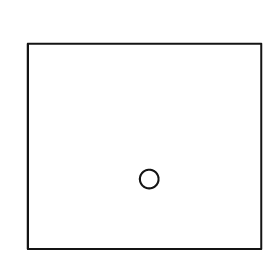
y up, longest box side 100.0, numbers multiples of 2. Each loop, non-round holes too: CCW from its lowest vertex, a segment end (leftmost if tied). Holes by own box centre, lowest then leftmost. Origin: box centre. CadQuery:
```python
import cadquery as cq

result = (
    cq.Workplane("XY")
    .moveTo(-50.0, -44.0)
    .lineTo(50.0, -44.0)
    .lineTo(50.0, 44.0)
    .lineTo(-50.0, 44.0)
    .close()
    .moveTo(2.0, -14.0)
    .circle(4.0)
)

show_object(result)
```